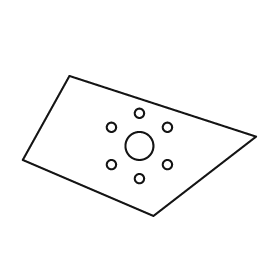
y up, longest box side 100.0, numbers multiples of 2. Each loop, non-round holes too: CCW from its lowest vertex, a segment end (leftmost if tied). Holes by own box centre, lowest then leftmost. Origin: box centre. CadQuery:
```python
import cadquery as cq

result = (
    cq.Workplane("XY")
    .moveTo(6.0, -30.0)
    .lineTo(50.0, 4.0)
    .lineTo(-30.0, 30.0)
    .lineTo(-50.0, -6.0)
    .close()
    .moveTo(0.0, -14.0)
    .circle(2.0)
    .moveTo(-12.0, -8.0)
    .circle(2.0)
    .moveTo(12.0, -8.0)
    .circle(2.0)
    .moveTo(0.0, 0.0)
    .circle(6.0)
    .moveTo(-12.0, 8.0)
    .circle(2.0)
    .moveTo(12.0, 8.0)
    .circle(2.0)
    .moveTo(0.0, 14.0)
    .circle(2.0)
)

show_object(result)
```